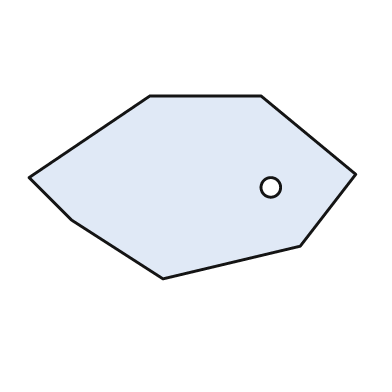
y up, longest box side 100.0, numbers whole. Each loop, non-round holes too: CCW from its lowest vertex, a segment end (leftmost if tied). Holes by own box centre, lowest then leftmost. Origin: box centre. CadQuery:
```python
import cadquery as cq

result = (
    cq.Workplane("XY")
    .moveTo(-9.0, -28.0)
    .lineTo(33.0, -18.0)
    .lineTo(50.0, 4.0)
    .lineTo(21.0, 28.0)
    .lineTo(-13.0, 28.0)
    .lineTo(-50.0, 3.0)
    .lineTo(-37.0, -10.0)
    .close()
    .moveTo(24.0, 0.0)
    .circle(3.0)
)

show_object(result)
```